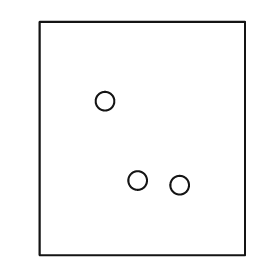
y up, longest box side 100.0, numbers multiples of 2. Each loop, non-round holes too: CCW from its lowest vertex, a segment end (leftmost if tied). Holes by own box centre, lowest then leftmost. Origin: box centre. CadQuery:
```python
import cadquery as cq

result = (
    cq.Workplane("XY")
    .moveTo(-44.0, -50.0)
    .lineTo(44.0, -50.0)
    .lineTo(44.0, 50.0)
    .lineTo(-44.0, 50.0)
    .close()
    .moveTo(16.0, -20.0)
    .circle(4.0)
    .moveTo(-2.0, -18.0)
    .circle(4.0)
    .moveTo(-16.0, 16.0)
    .circle(4.0)
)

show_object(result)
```